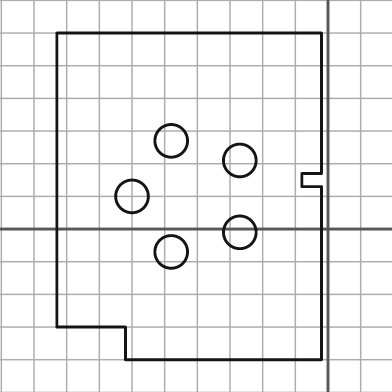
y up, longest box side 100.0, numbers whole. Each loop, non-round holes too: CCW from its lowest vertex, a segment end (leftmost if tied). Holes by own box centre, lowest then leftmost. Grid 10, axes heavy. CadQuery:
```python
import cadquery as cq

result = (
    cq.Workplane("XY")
    .moveTo(-62.0, -40.0)
    .lineTo(-2.0, -40.0)
    .lineTo(-2.0, 13.0)
    .lineTo(-8.0, 13.0)
    .lineTo(-8.0, 17.0)
    .lineTo(-2.0, 17.0)
    .lineTo(-2.0, 60.0)
    .lineTo(-83.0, 60.0)
    .lineTo(-83.0, -30.0)
    .lineTo(-62.0, -30.0)
    .close()
    .moveTo(-48.0, -7.0)
    .circle(5.0)
    .moveTo(-27.0, -1.0)
    .circle(5.0)
    .moveTo(-60.0, 10.0)
    .circle(5.0)
    .moveTo(-27.0, 21.0)
    .circle(5.0)
    .moveTo(-48.0, 27.0)
    .circle(5.0)
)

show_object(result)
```